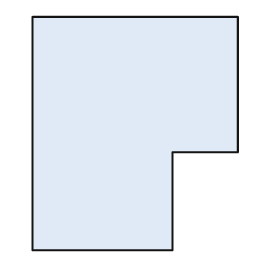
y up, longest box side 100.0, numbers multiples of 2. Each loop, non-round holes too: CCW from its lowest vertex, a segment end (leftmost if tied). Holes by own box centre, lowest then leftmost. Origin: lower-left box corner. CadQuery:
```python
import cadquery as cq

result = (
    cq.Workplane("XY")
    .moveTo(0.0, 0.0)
    .lineTo(60.0, 0.0)
    .lineTo(60.0, 42.0)
    .lineTo(88.0, 42.0)
    .lineTo(88.0, 100.0)
    .lineTo(0.0, 100.0)
    .close()
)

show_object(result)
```